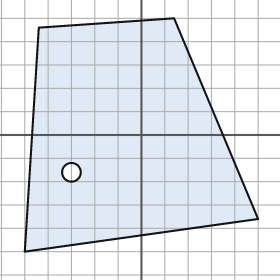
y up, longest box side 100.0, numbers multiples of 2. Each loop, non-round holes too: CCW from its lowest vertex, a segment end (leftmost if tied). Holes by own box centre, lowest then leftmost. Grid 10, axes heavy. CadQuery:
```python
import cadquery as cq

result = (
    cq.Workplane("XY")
    .moveTo(-50.0, -50.0)
    .lineTo(50.0, -36.0)
    .lineTo(14.0, 50.0)
    .lineTo(-44.0, 46.0)
    .close()
    .moveTo(-30.0, -16.0)
    .circle(4.0)
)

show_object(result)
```